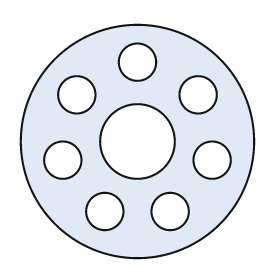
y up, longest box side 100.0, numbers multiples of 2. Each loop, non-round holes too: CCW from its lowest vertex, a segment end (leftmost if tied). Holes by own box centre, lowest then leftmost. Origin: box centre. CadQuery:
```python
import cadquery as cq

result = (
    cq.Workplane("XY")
    .moveTo(0.0, 0.0)
    .circle(50.0)
    .moveTo(-14.0, -30.0)
    .circle(8.0)
    .moveTo(14.0, -30.0)
    .circle(8.0)
    .moveTo(-32.0, -8.0)
    .circle(8.0)
    .moveTo(32.0, -8.0)
    .circle(8.0)
    .moveTo(0.0, 0.0)
    .circle(16.0)
    .moveTo(-26.0, 20.0)
    .circle(8.0)
    .moveTo(26.0, 20.0)
    .circle(8.0)
    .moveTo(0.0, 34.0)
    .circle(8.0)
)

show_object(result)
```